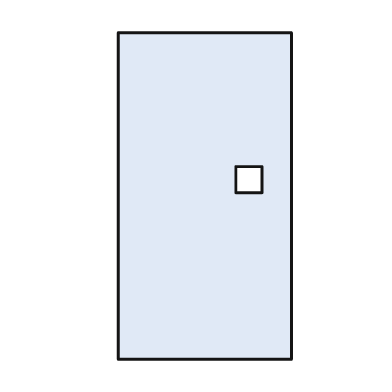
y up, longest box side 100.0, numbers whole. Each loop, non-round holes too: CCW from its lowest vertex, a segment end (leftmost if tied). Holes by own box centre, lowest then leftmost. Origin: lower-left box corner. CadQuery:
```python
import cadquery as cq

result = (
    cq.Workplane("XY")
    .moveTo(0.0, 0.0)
    .lineTo(53.0, 0.0)
    .lineTo(53.0, 100.0)
    .lineTo(0.0, 100.0)
    .close()
    .moveTo(36.0, 51.0)
    .lineTo(44.0, 51.0)
    .lineTo(44.0, 59.0)
    .lineTo(36.0, 59.0)
    .close()
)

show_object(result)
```